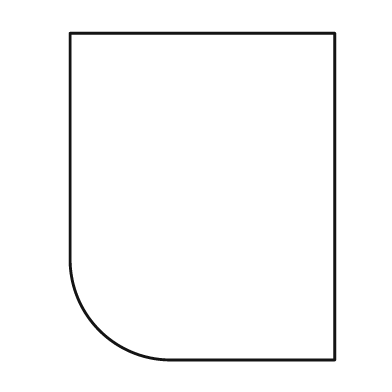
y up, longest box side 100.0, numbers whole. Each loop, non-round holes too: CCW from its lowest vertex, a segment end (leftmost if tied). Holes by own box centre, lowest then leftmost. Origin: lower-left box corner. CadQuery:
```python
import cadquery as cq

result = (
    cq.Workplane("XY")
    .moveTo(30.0, 0.0)
    .lineTo(81.0, 0.0)
    .lineTo(81.0, 100.0)
    .lineTo(0.0, 100.0)
    .lineTo(0.0, 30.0)
    .threePointArc((9.0, 9.0), (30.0, 0.0))
    .close()
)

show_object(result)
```